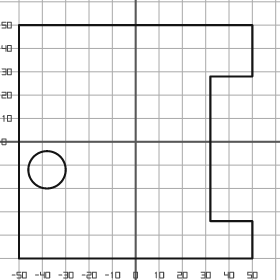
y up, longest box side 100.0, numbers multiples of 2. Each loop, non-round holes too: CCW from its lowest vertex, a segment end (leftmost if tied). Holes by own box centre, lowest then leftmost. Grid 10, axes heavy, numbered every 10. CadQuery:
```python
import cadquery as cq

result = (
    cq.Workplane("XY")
    .moveTo(-50.0, -50.0)
    .lineTo(50.0, -50.0)
    .lineTo(50.0, -34.0)
    .lineTo(32.0, -34.0)
    .lineTo(32.0, 28.0)
    .lineTo(50.0, 28.0)
    .lineTo(50.0, 50.0)
    .lineTo(-50.0, 50.0)
    .close()
    .moveTo(-38.0, -12.0)
    .circle(8.0)
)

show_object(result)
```